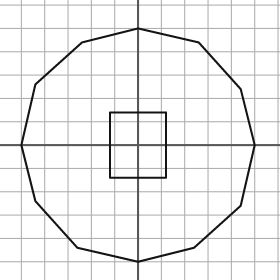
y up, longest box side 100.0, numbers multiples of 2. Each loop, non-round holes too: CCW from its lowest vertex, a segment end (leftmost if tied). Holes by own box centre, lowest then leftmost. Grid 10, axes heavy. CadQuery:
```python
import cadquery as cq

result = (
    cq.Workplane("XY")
    .moveTo(0.0, -50.0)
    .lineTo(24.0, -44.0)
    .lineTo(44.0, -26.0)
    .lineTo(50.0, 0.0)
    .lineTo(44.0, 24.0)
    .lineTo(26.0, 44.0)
    .lineTo(0.0, 50.0)
    .lineTo(-24.0, 44.0)
    .lineTo(-44.0, 26.0)
    .lineTo(-50.0, 0.0)
    .lineTo(-44.0, -24.0)
    .lineTo(-26.0, -44.0)
    .close()
    .moveTo(-12.0, -14.0)
    .lineTo(12.0, -14.0)
    .lineTo(12.0, 14.0)
    .lineTo(-12.0, 14.0)
    .close()
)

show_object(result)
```